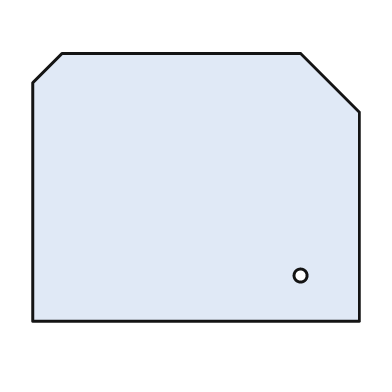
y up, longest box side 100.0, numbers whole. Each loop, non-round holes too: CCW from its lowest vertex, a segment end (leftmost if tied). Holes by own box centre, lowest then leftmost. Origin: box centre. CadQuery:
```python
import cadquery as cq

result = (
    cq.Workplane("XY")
    .moveTo(-50.0, -41.0)
    .lineTo(50.0, -41.0)
    .lineTo(50.0, 23.0)
    .lineTo(32.0, 41.0)
    .lineTo(-41.0, 41.0)
    .lineTo(-50.0, 32.0)
    .close()
    .moveTo(32.0, -27.0)
    .circle(2.0)
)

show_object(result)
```